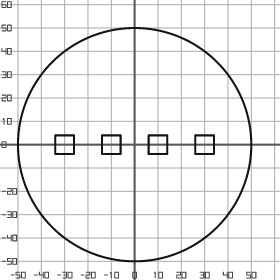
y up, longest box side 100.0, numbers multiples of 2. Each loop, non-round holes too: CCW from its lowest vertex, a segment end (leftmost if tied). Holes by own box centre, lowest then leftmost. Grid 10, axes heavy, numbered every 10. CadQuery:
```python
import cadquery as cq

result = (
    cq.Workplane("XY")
    .moveTo(0.0, 0.0)
    .circle(50.0)
    .moveTo(-34.0, -4.0)
    .lineTo(-26.0, -4.0)
    .lineTo(-26.0, 4.0)
    .lineTo(-34.0, 4.0)
    .close()
    .moveTo(-14.0, -4.0)
    .lineTo(-6.0, -4.0)
    .lineTo(-6.0, 4.0)
    .lineTo(-14.0, 4.0)
    .close()
    .moveTo(6.0, -4.0)
    .lineTo(14.0, -4.0)
    .lineTo(14.0, 4.0)
    .lineTo(6.0, 4.0)
    .close()
    .moveTo(26.0, -4.0)
    .lineTo(34.0, -4.0)
    .lineTo(34.0, 4.0)
    .lineTo(26.0, 4.0)
    .close()
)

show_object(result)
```